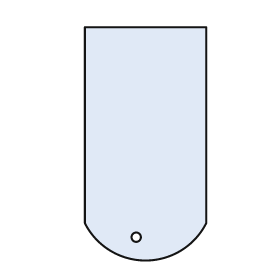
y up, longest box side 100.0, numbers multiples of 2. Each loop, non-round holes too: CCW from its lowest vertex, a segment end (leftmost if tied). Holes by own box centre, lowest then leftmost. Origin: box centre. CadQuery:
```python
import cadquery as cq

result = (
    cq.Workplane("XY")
    .moveTo(-26.0, -34.0)
    .threePointArc((0.0, -50.0), (26.0, -34.0))
    .lineTo(26.0, 50.0)
    .lineTo(-26.0, 50.0)
    .close()
    .moveTo(-4.0, -40.0)
    .circle(2.0)
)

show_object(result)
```